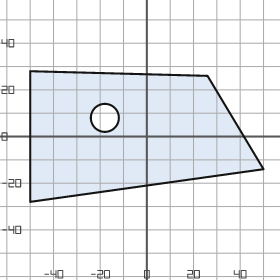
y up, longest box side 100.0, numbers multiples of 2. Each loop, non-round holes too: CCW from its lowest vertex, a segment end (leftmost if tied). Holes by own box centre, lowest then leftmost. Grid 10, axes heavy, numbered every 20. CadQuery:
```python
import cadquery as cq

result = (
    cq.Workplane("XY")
    .moveTo(-50.0, -28.0)
    .lineTo(50.0, -14.0)
    .lineTo(26.0, 26.0)
    .lineTo(-50.0, 28.0)
    .close()
    .moveTo(-18.0, 8.0)
    .circle(6.0)
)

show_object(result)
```